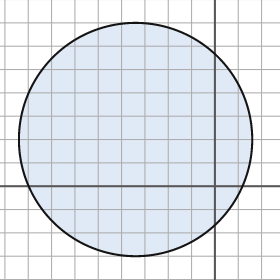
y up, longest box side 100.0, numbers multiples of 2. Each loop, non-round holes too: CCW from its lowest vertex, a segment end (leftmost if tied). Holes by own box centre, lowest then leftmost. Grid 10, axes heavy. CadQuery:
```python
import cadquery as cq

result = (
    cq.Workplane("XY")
    .moveTo(-34.0, 20.0)
    .circle(50.0)
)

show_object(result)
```